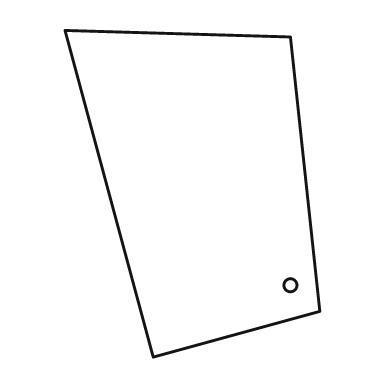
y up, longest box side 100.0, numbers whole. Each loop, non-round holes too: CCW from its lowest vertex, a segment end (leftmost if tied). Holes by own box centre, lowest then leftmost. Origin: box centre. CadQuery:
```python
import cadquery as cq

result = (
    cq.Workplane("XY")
    .moveTo(-12.0, -50.0)
    .lineTo(39.0, -36.0)
    .lineTo(30.0, 48.0)
    .lineTo(-39.0, 50.0)
    .close()
    .moveTo(30.0, -28.0)
    .circle(2.0)
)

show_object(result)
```